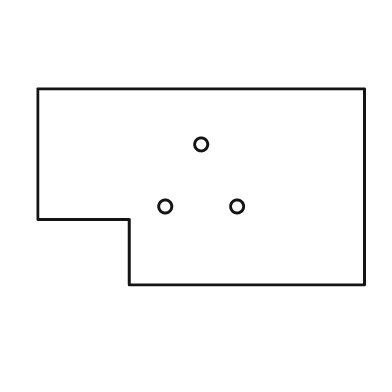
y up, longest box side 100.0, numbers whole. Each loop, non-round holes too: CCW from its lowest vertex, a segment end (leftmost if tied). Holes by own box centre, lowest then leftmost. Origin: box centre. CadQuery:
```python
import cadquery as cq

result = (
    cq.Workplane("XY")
    .moveTo(-22.0, -30.0)
    .lineTo(50.0, -30.0)
    .lineTo(50.0, 30.0)
    .lineTo(-50.0, 30.0)
    .lineTo(-50.0, -10.0)
    .lineTo(-22.0, -10.0)
    .close()
    .moveTo(-11.0, -6.0)
    .circle(2.0)
    .moveTo(11.0, -6.0)
    .circle(2.0)
    .moveTo(0.0, 13.0)
    .circle(2.0)
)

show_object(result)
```